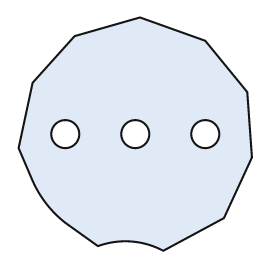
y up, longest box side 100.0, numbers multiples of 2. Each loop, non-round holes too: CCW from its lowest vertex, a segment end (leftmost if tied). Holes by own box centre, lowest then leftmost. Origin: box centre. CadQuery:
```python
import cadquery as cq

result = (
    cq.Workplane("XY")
    .moveTo(12.0, -50.0)
    .lineTo(38.0, -36.0)
    .lineTo(50.0, -10.0)
    .lineTo(48.0, 18.0)
    .lineTo(30.0, 40.0)
    .lineTo(2.0, 50.0)
    .lineTo(-26.0, 42.0)
    .lineTo(-44.0, 22.0)
    .lineTo(-50.0, -6.0)
    .lineTo(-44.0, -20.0)
    .threePointArc((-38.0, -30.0), (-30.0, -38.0))
    .lineTo(-16.0, -48.0)
    .threePointArc((-2.0, -46.0), (12.0, -50.0))
    .close()
    .moveTo(-30.0, 0.0)
    .circle(6.0)
    .moveTo(0.0, 0.0)
    .circle(6.0)
    .moveTo(30.0, 0.0)
    .circle(6.0)
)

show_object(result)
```